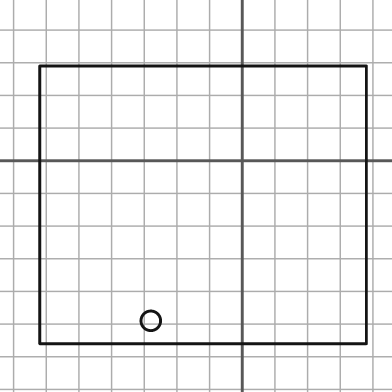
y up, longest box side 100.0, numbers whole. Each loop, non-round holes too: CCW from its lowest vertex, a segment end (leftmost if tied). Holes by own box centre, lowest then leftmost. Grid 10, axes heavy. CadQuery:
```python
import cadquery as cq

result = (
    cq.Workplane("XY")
    .moveTo(-62.0, -56.0)
    .lineTo(38.0, -56.0)
    .lineTo(38.0, 29.0)
    .lineTo(-62.0, 29.0)
    .close()
    .moveTo(-28.0, -49.0)
    .circle(3.0)
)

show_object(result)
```